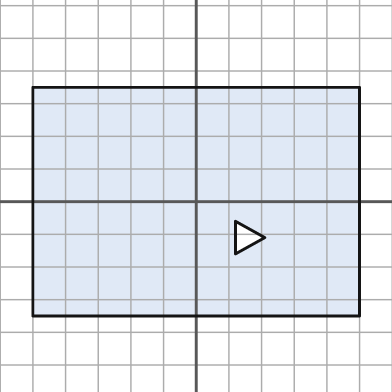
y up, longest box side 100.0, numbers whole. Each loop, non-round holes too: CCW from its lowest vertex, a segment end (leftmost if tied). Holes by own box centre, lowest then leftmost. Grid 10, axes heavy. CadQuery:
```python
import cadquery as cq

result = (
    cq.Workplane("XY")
    .moveTo(-50.0, -35.0)
    .lineTo(50.0, -35.0)
    .lineTo(50.0, 35.0)
    .lineTo(-50.0, 35.0)
    .close()
    .moveTo(12.0, -16.0)
    .lineTo(21.0, -11.0)
    .lineTo(12.0, -6.0)
    .close()
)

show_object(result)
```